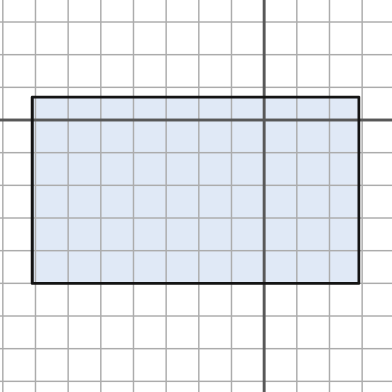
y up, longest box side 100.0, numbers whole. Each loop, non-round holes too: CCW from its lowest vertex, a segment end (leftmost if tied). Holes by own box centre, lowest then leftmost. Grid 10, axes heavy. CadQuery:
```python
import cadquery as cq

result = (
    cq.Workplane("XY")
    .moveTo(-71.0, -50.0)
    .lineTo(29.0, -50.0)
    .lineTo(29.0, 7.0)
    .lineTo(-71.0, 7.0)
    .close()
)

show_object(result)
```